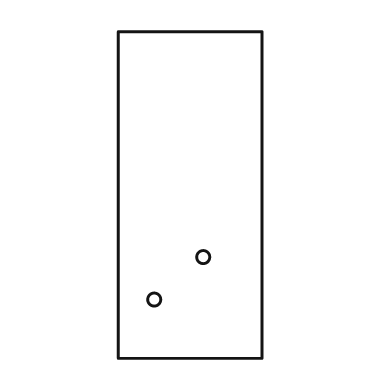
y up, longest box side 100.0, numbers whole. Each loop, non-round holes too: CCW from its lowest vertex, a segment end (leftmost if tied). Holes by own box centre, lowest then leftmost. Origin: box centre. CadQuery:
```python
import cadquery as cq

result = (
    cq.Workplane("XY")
    .moveTo(-22.0, -50.0)
    .lineTo(22.0, -50.0)
    .lineTo(22.0, 50.0)
    .lineTo(-22.0, 50.0)
    .close()
    .moveTo(-11.0, -32.0)
    .circle(2.0)
    .moveTo(4.0, -19.0)
    .circle(2.0)
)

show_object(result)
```